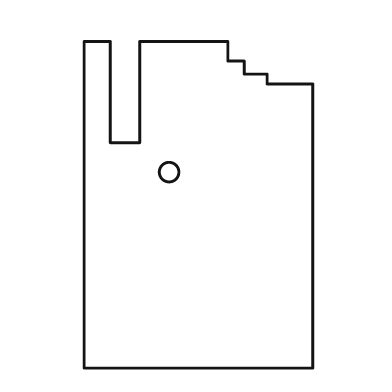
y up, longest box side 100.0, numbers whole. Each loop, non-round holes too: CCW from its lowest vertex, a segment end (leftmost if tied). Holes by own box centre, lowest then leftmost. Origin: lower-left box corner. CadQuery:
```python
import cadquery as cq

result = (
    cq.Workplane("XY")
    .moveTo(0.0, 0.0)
    .lineTo(70.0, 0.0)
    .lineTo(70.0, 87.0)
    .lineTo(56.0, 87.0)
    .lineTo(56.0, 90.0)
    .lineTo(49.0, 90.0)
    .lineTo(49.0, 94.0)
    .lineTo(44.0, 94.0)
    .lineTo(44.0, 100.0)
    .lineTo(17.0, 100.0)
    .lineTo(17.0, 69.0)
    .lineTo(8.0, 69.0)
    .lineTo(8.0, 100.0)
    .lineTo(0.0, 100.0)
    .close()
    .moveTo(26.0, 60.0)
    .circle(3.0)
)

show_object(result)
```